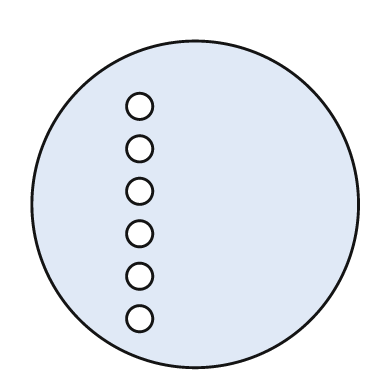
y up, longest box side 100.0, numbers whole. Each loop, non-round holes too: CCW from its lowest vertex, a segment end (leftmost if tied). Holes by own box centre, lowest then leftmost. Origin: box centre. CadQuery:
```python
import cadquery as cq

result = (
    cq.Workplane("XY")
    .moveTo(0.0, 0.0)
    .circle(50.0)
    .moveTo(-17.0, -35.0)
    .circle(4.0)
    .moveTo(-17.0, -22.0)
    .circle(4.0)
    .moveTo(-17.0, -9.0)
    .circle(4.0)
    .moveTo(-17.0, 4.0)
    .circle(4.0)
    .moveTo(-17.0, 17.0)
    .circle(4.0)
    .moveTo(-17.0, 30.0)
    .circle(4.0)
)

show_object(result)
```